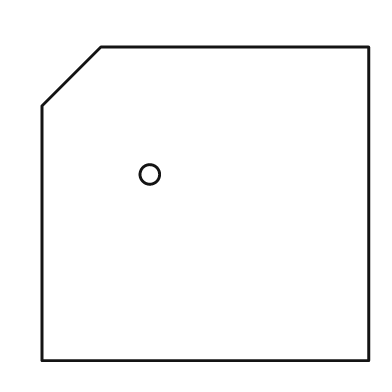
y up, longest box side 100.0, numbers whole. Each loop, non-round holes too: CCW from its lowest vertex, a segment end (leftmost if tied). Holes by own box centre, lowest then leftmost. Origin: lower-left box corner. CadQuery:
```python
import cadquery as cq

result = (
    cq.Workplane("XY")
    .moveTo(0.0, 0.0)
    .lineTo(100.0, 0.0)
    .lineTo(100.0, 96.0)
    .lineTo(18.0, 96.0)
    .lineTo(0.0, 78.0)
    .close()
    .moveTo(33.0, 57.0)
    .circle(3.0)
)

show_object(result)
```